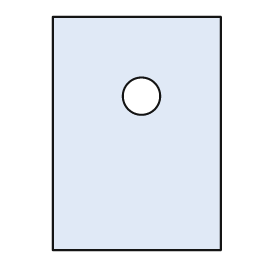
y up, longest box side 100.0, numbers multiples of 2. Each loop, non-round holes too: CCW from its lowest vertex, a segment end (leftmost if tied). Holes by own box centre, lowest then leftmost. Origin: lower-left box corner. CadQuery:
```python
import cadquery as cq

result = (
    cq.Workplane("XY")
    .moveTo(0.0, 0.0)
    .lineTo(72.0, 0.0)
    .lineTo(72.0, 100.0)
    .lineTo(0.0, 100.0)
    .close()
    .moveTo(38.0, 66.0)
    .circle(8.0)
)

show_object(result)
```